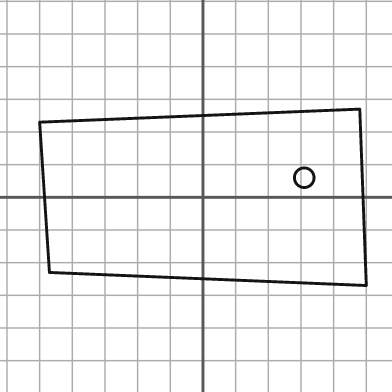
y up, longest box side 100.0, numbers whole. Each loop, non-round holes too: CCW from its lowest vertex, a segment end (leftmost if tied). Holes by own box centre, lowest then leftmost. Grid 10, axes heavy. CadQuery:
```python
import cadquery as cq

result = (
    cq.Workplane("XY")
    .moveTo(50.0, -27.0)
    .lineTo(48.0, 27.0)
    .lineTo(-50.0, 23.0)
    .lineTo(-47.0, -23.0)
    .close()
    .moveTo(31.0, 6.0)
    .circle(3.0)
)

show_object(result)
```